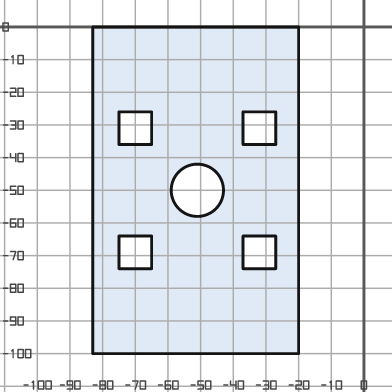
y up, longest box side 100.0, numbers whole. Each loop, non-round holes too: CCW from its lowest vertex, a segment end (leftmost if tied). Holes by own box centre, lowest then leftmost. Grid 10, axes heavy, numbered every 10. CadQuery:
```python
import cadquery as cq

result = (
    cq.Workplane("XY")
    .moveTo(-83.0, -100.0)
    .lineTo(-20.0, -100.0)
    .lineTo(-20.0, 0.0)
    .lineTo(-83.0, 0.0)
    .close()
    .moveTo(-75.0, -74.0)
    .lineTo(-65.0, -74.0)
    .lineTo(-65.0, -64.0)
    .lineTo(-75.0, -64.0)
    .close()
    .moveTo(-37.0, -74.0)
    .lineTo(-27.0, -74.0)
    .lineTo(-27.0, -64.0)
    .lineTo(-37.0, -64.0)
    .close()
    .moveTo(-51.0, -50.0)
    .circle(8.0)
    .moveTo(-75.0, -36.0)
    .lineTo(-65.0, -36.0)
    .lineTo(-65.0, -26.0)
    .lineTo(-75.0, -26.0)
    .close()
    .moveTo(-37.0, -36.0)
    .lineTo(-27.0, -36.0)
    .lineTo(-27.0, -26.0)
    .lineTo(-37.0, -26.0)
    .close()
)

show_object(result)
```